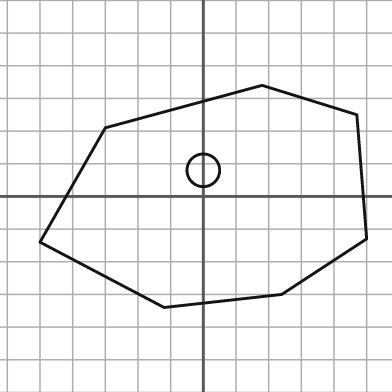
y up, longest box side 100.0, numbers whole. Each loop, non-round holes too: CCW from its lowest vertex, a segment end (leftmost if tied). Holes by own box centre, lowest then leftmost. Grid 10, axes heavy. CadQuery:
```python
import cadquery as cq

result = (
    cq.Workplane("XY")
    .moveTo(-12.0, -34.0)
    .lineTo(24.0, -30.0)
    .lineTo(50.0, -13.0)
    .lineTo(47.0, 25.0)
    .lineTo(18.0, 34.0)
    .lineTo(-30.0, 21.0)
    .lineTo(-50.0, -14.0)
    .close()
    .moveTo(0.0, 8.0)
    .circle(5.0)
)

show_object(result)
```